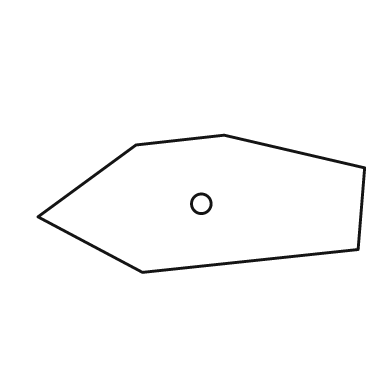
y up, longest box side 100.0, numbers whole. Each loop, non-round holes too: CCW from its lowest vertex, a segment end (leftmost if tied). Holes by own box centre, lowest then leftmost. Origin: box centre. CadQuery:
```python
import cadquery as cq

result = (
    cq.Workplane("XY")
    .moveTo(-18.0, -21.0)
    .lineTo(48.0, -14.0)
    .lineTo(50.0, 11.0)
    .lineTo(7.0, 21.0)
    .lineTo(-20.0, 18.0)
    .lineTo(-50.0, -4.0)
    .close()
    .moveTo(0.0, 0.0)
    .circle(3.0)
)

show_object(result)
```